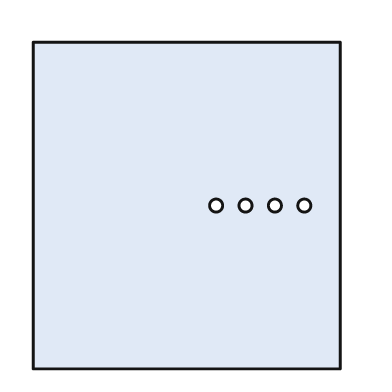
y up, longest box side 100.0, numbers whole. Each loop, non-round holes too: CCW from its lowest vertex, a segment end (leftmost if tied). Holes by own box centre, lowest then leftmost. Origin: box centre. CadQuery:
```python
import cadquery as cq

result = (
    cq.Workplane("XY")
    .moveTo(-47.0, -50.0)
    .lineTo(47.0, -50.0)
    .lineTo(47.0, 50.0)
    .lineTo(-47.0, 50.0)
    .close()
    .moveTo(9.0, 0.0)
    .circle(2.0)
    .moveTo(18.0, 0.0)
    .circle(2.0)
    .moveTo(27.0, 0.0)
    .circle(2.0)
    .moveTo(36.0, 0.0)
    .circle(2.0)
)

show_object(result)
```